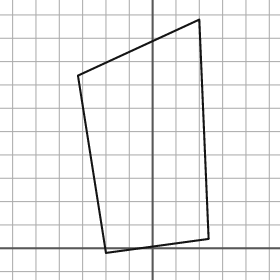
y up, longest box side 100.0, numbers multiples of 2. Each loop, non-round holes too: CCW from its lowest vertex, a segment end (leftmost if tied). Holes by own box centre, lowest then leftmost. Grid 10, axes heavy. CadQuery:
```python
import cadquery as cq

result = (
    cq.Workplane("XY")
    .moveTo(-20.0, -2.0)
    .lineTo(24.0, 4.0)
    .lineTo(20.0, 98.0)
    .lineTo(-32.0, 74.0)
    .close()
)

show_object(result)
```